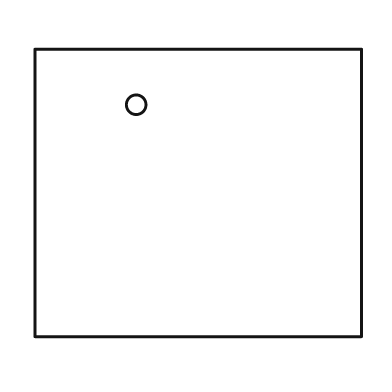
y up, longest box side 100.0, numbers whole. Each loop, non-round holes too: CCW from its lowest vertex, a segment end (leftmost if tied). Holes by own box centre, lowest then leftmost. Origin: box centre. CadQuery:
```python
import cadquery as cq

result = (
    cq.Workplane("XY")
    .moveTo(-50.0, -44.0)
    .lineTo(50.0, -44.0)
    .lineTo(50.0, 44.0)
    .lineTo(-50.0, 44.0)
    .close()
    .moveTo(-19.0, 27.0)
    .circle(3.0)
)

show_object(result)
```